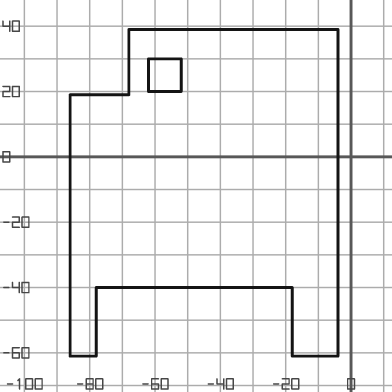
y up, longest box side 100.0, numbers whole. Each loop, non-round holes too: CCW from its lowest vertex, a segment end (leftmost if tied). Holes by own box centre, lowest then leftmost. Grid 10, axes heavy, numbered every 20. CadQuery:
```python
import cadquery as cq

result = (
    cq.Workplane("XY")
    .moveTo(-86.0, -61.0)
    .lineTo(-78.0, -61.0)
    .lineTo(-78.0, -40.0)
    .lineTo(-18.0, -40.0)
    .lineTo(-18.0, -61.0)
    .lineTo(-4.0, -61.0)
    .lineTo(-4.0, 39.0)
    .lineTo(-68.0, 39.0)
    .lineTo(-68.0, 19.0)
    .lineTo(-86.0, 19.0)
    .close()
    .moveTo(-62.0, 20.0)
    .lineTo(-52.0, 20.0)
    .lineTo(-52.0, 30.0)
    .lineTo(-62.0, 30.0)
    .close()
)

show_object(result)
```